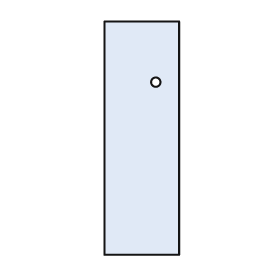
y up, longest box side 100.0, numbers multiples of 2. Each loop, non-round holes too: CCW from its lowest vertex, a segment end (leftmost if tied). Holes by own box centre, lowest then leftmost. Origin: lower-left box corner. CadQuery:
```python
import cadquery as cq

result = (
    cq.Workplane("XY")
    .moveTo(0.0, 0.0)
    .lineTo(32.0, 0.0)
    .lineTo(32.0, 100.0)
    .lineTo(0.0, 100.0)
    .close()
    .moveTo(22.0, 74.0)
    .circle(2.0)
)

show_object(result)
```